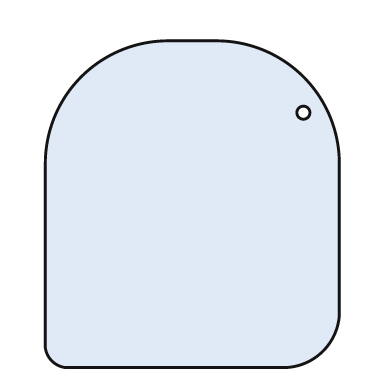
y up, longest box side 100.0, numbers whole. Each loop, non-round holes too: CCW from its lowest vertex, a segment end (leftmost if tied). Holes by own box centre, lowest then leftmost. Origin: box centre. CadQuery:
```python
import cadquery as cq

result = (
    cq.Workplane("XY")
    .moveTo(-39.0, -50.0)
    .lineTo(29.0, -50.0)
    .threePointArc((40.0, -45.0), (45.0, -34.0))
    .lineTo(45.0, 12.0)
    .threePointArc((34.0, 39.0), (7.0, 50.0))
    .lineTo(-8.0, 50.0)
    .threePointArc((-34.0, 39.0), (-45.0, 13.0))
    .lineTo(-45.0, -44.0)
    .threePointArc((-43.0, -48.0), (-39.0, -50.0))
    .close()
    .moveTo(34.0, 28.0)
    .circle(2.0)
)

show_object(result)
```